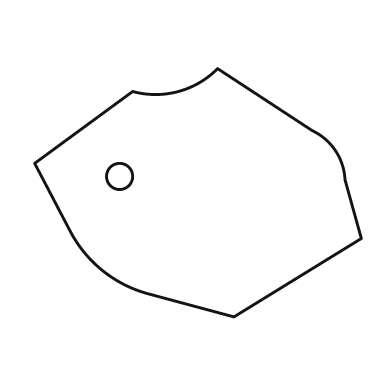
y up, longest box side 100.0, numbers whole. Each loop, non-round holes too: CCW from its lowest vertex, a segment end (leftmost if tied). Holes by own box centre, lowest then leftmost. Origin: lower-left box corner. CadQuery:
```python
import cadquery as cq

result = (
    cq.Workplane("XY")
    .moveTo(61.0, 0.0)
    .lineTo(100.0, 24.0)
    .lineTo(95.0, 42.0)
    .threePointArc((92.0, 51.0), (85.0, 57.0))
    .lineTo(56.0, 76.0)
    .threePointArc((44.0, 69.0), (30.0, 69.0))
    .lineTo(0.0, 47.0)
    .lineTo(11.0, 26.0)
    .threePointArc((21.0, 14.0), (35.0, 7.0))
    .close()
    .moveTo(26.0, 43.0)
    .circle(4.0)
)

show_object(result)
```